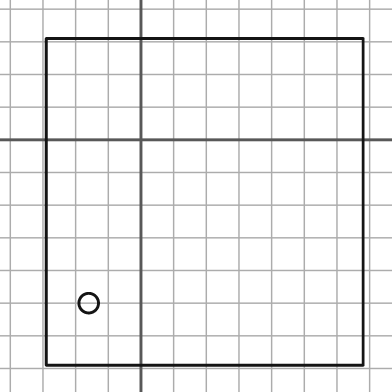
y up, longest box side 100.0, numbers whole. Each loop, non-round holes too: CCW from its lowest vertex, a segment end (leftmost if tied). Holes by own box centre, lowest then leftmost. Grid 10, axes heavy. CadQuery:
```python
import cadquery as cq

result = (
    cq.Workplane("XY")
    .moveTo(-29.0, -69.0)
    .lineTo(68.0, -69.0)
    .lineTo(68.0, 31.0)
    .lineTo(-29.0, 31.0)
    .close()
    .moveTo(-16.0, -50.0)
    .circle(3.0)
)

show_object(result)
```